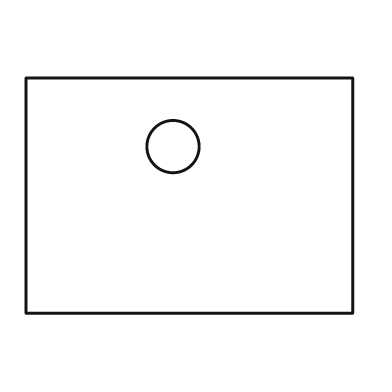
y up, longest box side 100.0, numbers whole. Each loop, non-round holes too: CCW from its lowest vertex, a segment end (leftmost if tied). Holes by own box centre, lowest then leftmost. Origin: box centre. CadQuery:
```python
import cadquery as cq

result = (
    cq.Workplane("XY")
    .moveTo(-50.0, -36.0)
    .lineTo(50.0, -36.0)
    .lineTo(50.0, 36.0)
    .lineTo(-50.0, 36.0)
    .close()
    .moveTo(-5.0, 15.0)
    .circle(8.0)
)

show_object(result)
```